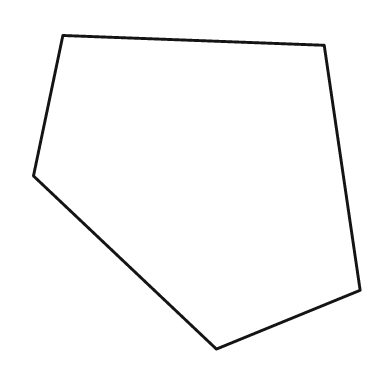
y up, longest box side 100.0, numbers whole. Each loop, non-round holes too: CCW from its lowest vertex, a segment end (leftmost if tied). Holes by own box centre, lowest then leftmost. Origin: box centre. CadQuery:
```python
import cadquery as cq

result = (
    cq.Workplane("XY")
    .moveTo(6.0, -48.0)
    .lineTo(50.0, -30.0)
    .lineTo(39.0, 45.0)
    .lineTo(-41.0, 48.0)
    .lineTo(-50.0, 5.0)
    .close()
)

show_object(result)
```